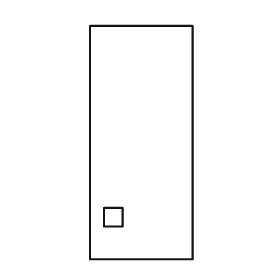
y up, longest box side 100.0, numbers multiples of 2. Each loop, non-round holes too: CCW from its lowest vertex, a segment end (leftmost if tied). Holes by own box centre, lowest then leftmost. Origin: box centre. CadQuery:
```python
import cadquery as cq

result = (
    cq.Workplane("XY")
    .moveTo(-22.0, -50.0)
    .lineTo(22.0, -50.0)
    .lineTo(22.0, 50.0)
    .lineTo(-22.0, 50.0)
    .close()
    .moveTo(-16.0, -36.0)
    .lineTo(-8.0, -36.0)
    .lineTo(-8.0, -28.0)
    .lineTo(-16.0, -28.0)
    .close()
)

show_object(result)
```